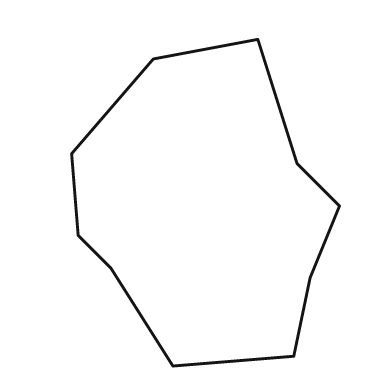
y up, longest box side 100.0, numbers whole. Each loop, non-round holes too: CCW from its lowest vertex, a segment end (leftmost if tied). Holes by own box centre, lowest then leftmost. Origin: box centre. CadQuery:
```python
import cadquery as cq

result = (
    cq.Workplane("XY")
    .moveTo(-10.0, -50.0)
    .lineTo(27.0, -47.0)
    .lineTo(32.0, -23.0)
    .lineTo(41.0, -1.0)
    .lineTo(28.0, 12.0)
    .lineTo(16.0, 50.0)
    .lineTo(-16.0, 44.0)
    .lineTo(-41.0, 15.0)
    .lineTo(-39.0, -10.0)
    .lineTo(-29.0, -20.0)
    .close()
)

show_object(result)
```